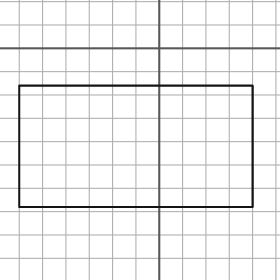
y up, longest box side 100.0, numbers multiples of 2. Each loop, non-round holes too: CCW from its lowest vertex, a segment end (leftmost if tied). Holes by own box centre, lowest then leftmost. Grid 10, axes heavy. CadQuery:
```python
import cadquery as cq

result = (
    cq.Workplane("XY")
    .moveTo(-60.0, -68.0)
    .lineTo(40.0, -68.0)
    .lineTo(40.0, -16.0)
    .lineTo(-60.0, -16.0)
    .close()
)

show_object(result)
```